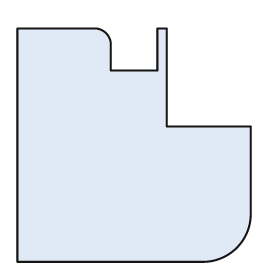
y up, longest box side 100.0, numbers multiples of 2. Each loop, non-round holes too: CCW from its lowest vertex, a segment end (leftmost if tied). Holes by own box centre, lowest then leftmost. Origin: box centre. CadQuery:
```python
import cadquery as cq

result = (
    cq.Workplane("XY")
    .moveTo(-50.0, -50.0)
    .lineTo(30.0, -50.0)
    .threePointArc((44.0, -44.0), (50.0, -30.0))
    .lineTo(50.0, 8.0)
    .lineTo(14.0, 8.0)
    .lineTo(14.0, 50.0)
    .lineTo(10.0, 50.0)
    .lineTo(10.0, 32.0)
    .lineTo(-10.0, 32.0)
    .lineTo(-10.0, 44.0)
    .threePointArc((-12.0, 48.0), (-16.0, 50.0))
    .lineTo(-50.0, 50.0)
    .close()
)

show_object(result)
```